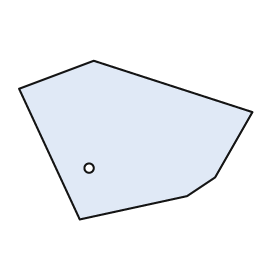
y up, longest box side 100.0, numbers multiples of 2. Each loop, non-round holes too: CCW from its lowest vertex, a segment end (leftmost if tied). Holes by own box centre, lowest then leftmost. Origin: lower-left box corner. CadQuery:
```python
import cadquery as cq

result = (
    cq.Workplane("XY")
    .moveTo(26.0, 0.0)
    .lineTo(72.0, 10.0)
    .lineTo(84.0, 18.0)
    .lineTo(100.0, 46.0)
    .lineTo(32.0, 68.0)
    .lineTo(0.0, 56.0)
    .close()
    .moveTo(30.0, 22.0)
    .circle(2.0)
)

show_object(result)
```